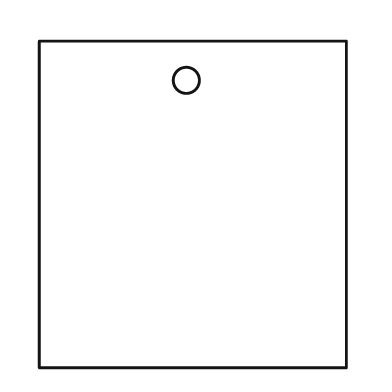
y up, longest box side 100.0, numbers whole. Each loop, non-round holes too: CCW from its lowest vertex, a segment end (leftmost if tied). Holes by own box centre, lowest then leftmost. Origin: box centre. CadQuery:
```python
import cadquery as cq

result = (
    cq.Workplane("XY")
    .moveTo(-47.0, -50.0)
    .lineTo(47.0, -50.0)
    .lineTo(47.0, 50.0)
    .lineTo(-47.0, 50.0)
    .close()
    .moveTo(-2.0, 38.0)
    .circle(4.0)
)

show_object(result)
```